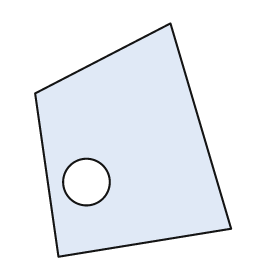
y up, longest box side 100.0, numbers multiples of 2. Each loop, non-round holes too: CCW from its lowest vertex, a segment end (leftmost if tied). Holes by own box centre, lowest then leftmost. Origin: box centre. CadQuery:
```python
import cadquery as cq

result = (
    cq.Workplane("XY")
    .moveTo(-32.0, -50.0)
    .lineTo(42.0, -38.0)
    .lineTo(16.0, 50.0)
    .lineTo(-42.0, 20.0)
    .close()
    .moveTo(-20.0, -18.0)
    .circle(10.0)
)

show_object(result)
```